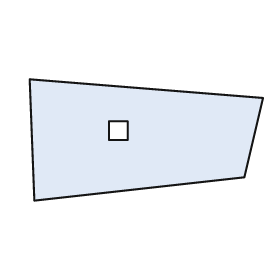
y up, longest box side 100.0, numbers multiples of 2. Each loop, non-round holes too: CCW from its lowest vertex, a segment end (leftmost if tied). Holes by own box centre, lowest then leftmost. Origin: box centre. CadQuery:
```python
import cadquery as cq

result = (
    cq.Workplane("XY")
    .moveTo(-48.0, -26.0)
    .lineTo(42.0, -16.0)
    .lineTo(50.0, 18.0)
    .lineTo(-50.0, 26.0)
    .close()
    .moveTo(-16.0, 0.0)
    .lineTo(-8.0, 0.0)
    .lineTo(-8.0, 8.0)
    .lineTo(-16.0, 8.0)
    .close()
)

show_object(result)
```